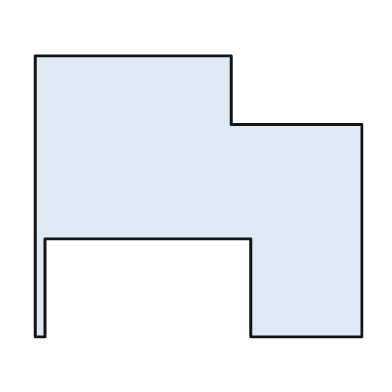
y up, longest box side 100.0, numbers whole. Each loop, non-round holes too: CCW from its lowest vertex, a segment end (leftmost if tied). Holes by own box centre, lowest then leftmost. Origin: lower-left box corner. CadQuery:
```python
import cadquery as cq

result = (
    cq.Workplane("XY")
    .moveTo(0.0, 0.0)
    .lineTo(3.0, 0.0)
    .lineTo(3.0, 30.0)
    .lineTo(66.0, 30.0)
    .lineTo(66.0, 0.0)
    .lineTo(100.0, 0.0)
    .lineTo(100.0, 65.0)
    .lineTo(60.0, 65.0)
    .lineTo(60.0, 86.0)
    .lineTo(0.0, 86.0)
    .close()
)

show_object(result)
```